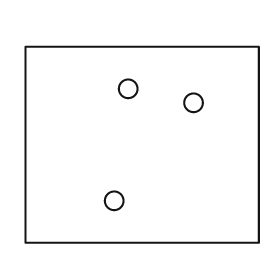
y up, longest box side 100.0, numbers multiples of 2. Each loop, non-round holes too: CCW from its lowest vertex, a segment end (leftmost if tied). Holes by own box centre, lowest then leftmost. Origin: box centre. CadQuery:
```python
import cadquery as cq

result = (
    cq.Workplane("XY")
    .moveTo(-50.0, -42.0)
    .lineTo(50.0, -42.0)
    .lineTo(50.0, 42.0)
    .lineTo(-50.0, 42.0)
    .close()
    .moveTo(-12.0, -24.0)
    .circle(4.0)
    .moveTo(22.0, 18.0)
    .circle(4.0)
    .moveTo(-6.0, 24.0)
    .circle(4.0)
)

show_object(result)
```